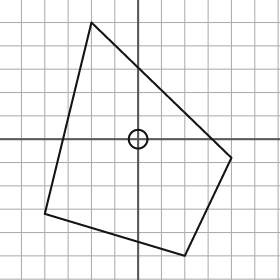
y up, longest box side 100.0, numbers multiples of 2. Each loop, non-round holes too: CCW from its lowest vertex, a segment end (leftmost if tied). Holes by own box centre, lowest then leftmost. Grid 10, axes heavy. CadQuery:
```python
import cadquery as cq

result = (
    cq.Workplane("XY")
    .moveTo(20.0, -50.0)
    .lineTo(40.0, -8.0)
    .lineTo(-20.0, 50.0)
    .lineTo(-40.0, -32.0)
    .close()
    .moveTo(0.0, 0.0)
    .circle(4.0)
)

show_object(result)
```